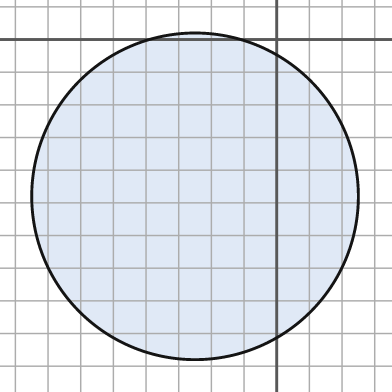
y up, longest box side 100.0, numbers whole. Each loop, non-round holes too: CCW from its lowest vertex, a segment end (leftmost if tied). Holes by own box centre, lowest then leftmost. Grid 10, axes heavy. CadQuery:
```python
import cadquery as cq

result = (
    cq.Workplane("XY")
    .moveTo(-25.0, -48.0)
    .circle(50.0)
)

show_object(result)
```